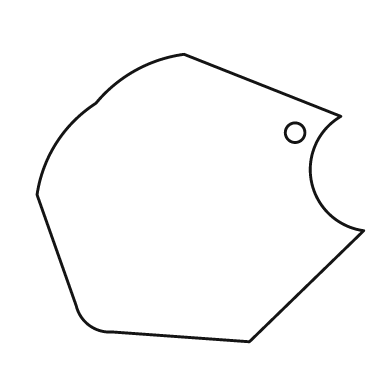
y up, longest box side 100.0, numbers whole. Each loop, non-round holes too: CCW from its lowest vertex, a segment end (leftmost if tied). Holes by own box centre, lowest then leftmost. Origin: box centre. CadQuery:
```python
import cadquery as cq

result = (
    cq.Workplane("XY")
    .moveTo(15.0, -44.0)
    .lineTo(50.0, -10.0)
    .threePointArc((34.0, 5.0), (43.0, 25.0))
    .lineTo(-5.0, 44.0)
    .threePointArc((-20.0, 39.0), (-32.0, 29.0))
    .threePointArc((-44.0, 17.0), (-50.0, 1.0))
    .lineTo(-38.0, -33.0)
    .threePointArc((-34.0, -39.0), (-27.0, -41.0))
    .close()
    .moveTo(29.0, 20.0)
    .circle(3.0)
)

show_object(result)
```